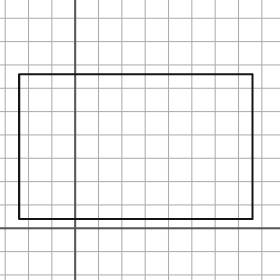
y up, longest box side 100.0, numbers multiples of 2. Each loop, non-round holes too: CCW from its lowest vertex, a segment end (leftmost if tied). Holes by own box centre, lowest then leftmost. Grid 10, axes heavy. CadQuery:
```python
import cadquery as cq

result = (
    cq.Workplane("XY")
    .moveTo(-24.0, 4.0)
    .lineTo(76.0, 4.0)
    .lineTo(76.0, 66.0)
    .lineTo(-24.0, 66.0)
    .close()
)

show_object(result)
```